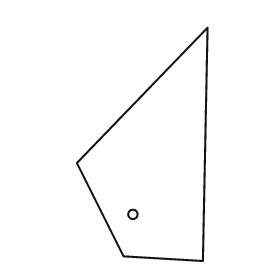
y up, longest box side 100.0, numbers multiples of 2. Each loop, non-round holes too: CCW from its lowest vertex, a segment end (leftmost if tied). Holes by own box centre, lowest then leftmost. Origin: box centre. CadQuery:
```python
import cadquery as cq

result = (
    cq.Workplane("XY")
    .moveTo(26.0, -50.0)
    .lineTo(28.0, 50.0)
    .lineTo(-28.0, -8.0)
    .lineTo(-8.0, -48.0)
    .close()
    .moveTo(-4.0, -30.0)
    .circle(2.0)
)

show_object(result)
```